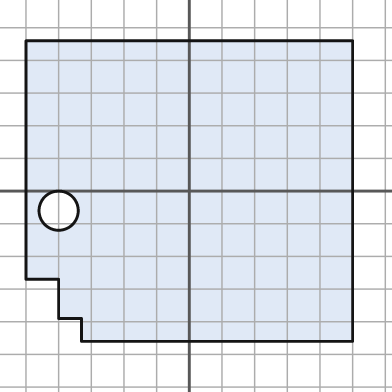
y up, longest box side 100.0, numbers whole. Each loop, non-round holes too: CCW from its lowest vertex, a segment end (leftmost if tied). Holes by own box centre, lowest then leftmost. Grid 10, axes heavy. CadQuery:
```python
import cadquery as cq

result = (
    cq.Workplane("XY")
    .moveTo(-33.0, -46.0)
    .lineTo(50.0, -46.0)
    .lineTo(50.0, 46.0)
    .lineTo(-50.0, 46.0)
    .lineTo(-50.0, -27.0)
    .lineTo(-40.0, -27.0)
    .lineTo(-40.0, -39.0)
    .lineTo(-33.0, -39.0)
    .close()
    .moveTo(-40.0, -6.0)
    .circle(6.0)
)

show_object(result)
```